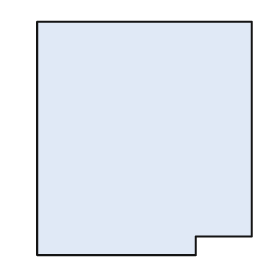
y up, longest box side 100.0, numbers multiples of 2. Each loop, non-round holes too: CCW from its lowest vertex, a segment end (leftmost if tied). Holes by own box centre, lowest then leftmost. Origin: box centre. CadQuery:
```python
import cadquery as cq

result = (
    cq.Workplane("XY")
    .moveTo(-46.0, -50.0)
    .lineTo(22.0, -50.0)
    .lineTo(22.0, -42.0)
    .lineTo(46.0, -42.0)
    .lineTo(46.0, 50.0)
    .lineTo(-46.0, 50.0)
    .close()
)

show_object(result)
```